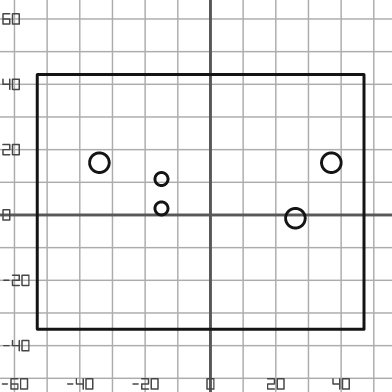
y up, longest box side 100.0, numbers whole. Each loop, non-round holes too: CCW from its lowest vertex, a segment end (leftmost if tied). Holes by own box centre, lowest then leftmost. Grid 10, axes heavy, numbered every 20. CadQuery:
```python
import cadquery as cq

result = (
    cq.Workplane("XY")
    .moveTo(-53.0, -35.0)
    .lineTo(47.0, -35.0)
    .lineTo(47.0, 43.0)
    .lineTo(-53.0, 43.0)
    .close()
    .moveTo(26.0, -1.0)
    .circle(3.0)
    .moveTo(-15.0, 2.0)
    .circle(2.0)
    .moveTo(-15.0, 11.0)
    .circle(2.0)
    .moveTo(-34.0, 16.0)
    .circle(3.0)
    .moveTo(37.0, 16.0)
    .circle(3.0)
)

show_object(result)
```